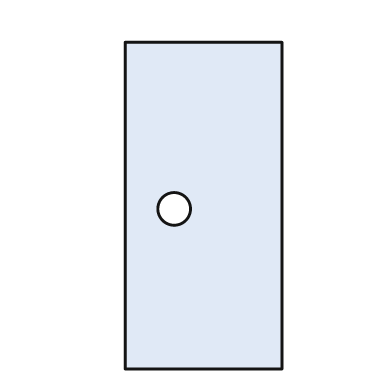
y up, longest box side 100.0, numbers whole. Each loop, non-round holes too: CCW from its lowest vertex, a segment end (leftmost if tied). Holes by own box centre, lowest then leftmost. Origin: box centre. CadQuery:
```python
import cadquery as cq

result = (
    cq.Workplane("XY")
    .moveTo(-24.0, -50.0)
    .lineTo(24.0, -50.0)
    .lineTo(24.0, 50.0)
    .lineTo(-24.0, 50.0)
    .close()
    .moveTo(-9.0, -1.0)
    .circle(5.0)
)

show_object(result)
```